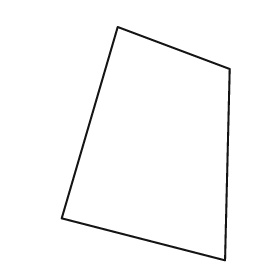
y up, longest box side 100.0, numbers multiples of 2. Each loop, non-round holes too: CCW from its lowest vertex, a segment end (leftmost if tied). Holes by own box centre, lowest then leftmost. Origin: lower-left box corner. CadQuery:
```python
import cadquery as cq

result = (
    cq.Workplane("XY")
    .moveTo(70.0, 0.0)
    .lineTo(72.0, 82.0)
    .lineTo(24.0, 100.0)
    .lineTo(0.0, 18.0)
    .close()
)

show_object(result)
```